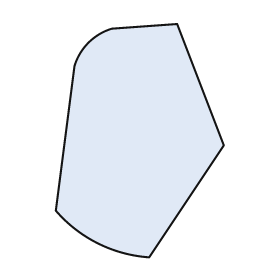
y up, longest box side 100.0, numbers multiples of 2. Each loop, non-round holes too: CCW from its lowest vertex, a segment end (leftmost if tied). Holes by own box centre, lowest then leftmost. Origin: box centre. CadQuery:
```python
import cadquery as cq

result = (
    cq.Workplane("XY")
    .moveTo(4.0, -50.0)
    .lineTo(36.0, -2.0)
    .lineTo(16.0, 50.0)
    .lineTo(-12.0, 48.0)
    .threePointArc((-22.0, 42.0), (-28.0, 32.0))
    .lineTo(-36.0, -30.0)
    .threePointArc((-18.0, -44.0), (4.0, -50.0))
    .close()
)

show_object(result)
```